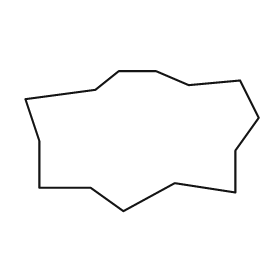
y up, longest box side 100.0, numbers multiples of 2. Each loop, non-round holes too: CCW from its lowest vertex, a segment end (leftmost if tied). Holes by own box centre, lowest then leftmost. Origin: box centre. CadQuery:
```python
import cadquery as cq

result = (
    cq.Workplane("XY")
    .moveTo(-8.0, -30.0)
    .lineTo(14.0, -18.0)
    .lineTo(40.0, -22.0)
    .lineTo(40.0, -4.0)
    .lineTo(50.0, 10.0)
    .lineTo(42.0, 26.0)
    .lineTo(20.0, 24.0)
    .lineTo(6.0, 30.0)
    .lineTo(-10.0, 30.0)
    .lineTo(-20.0, 22.0)
    .lineTo(-50.0, 18.0)
    .lineTo(-44.0, 0.0)
    .lineTo(-44.0, -20.0)
    .lineTo(-22.0, -20.0)
    .close()
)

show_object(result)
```